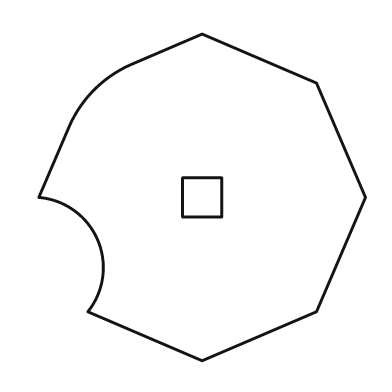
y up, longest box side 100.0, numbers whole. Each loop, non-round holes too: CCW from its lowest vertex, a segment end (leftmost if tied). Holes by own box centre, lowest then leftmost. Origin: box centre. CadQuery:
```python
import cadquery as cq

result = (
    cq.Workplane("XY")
    .moveTo(0.0, -50.0)
    .lineTo(35.0, -35.0)
    .lineTo(50.0, 0.0)
    .lineTo(35.0, 35.0)
    .lineTo(0.0, 50.0)
    .lineTo(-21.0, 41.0)
    .threePointArc((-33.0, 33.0), (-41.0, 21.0))
    .lineTo(-50.0, 0.0)
    .threePointArc((-32.0, -13.0), (-35.0, -35.0))
    .close()
    .moveTo(-6.0, -6.0)
    .lineTo(6.0, -6.0)
    .lineTo(6.0, 6.0)
    .lineTo(-6.0, 6.0)
    .close()
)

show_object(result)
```